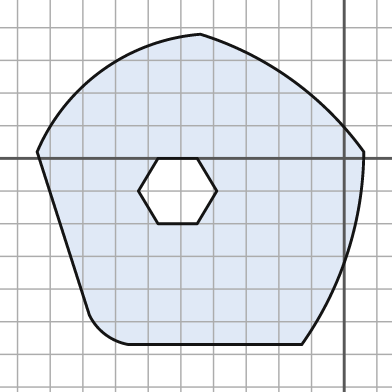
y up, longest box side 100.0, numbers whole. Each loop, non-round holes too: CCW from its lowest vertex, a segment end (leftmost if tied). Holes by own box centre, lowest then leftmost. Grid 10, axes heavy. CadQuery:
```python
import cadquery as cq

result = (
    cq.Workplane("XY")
    .moveTo(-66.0, -57.0)
    .lineTo(-13.0, -57.0)
    .threePointArc((1.0, -29.0), (6.0, 2.0))
    .threePointArc((-16.0, 24.0), (-44.0, 38.0))
    .threePointArc((-74.0, 27.0), (-94.0, 2.0))
    .lineTo(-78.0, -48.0)
    .threePointArc((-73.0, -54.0), (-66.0, -57.0))
    .close()
    .moveTo(-57.0, -20.0)
    .lineTo(-45.0, -20.0)
    .lineTo(-39.0, -10.0)
    .lineTo(-45.0, 0.0)
    .lineTo(-57.0, 0.0)
    .lineTo(-63.0, -10.0)
    .close()
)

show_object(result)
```